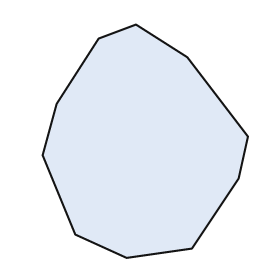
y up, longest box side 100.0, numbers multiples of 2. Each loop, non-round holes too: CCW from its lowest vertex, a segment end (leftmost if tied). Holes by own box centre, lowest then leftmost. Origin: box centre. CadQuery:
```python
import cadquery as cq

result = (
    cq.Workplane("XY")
    .moveTo(-8.0, -50.0)
    .lineTo(20.0, -46.0)
    .lineTo(40.0, -16.0)
    .lineTo(44.0, 2.0)
    .lineTo(18.0, 36.0)
    .lineTo(-4.0, 50.0)
    .lineTo(-20.0, 44.0)
    .lineTo(-38.0, 16.0)
    .lineTo(-44.0, -6.0)
    .lineTo(-30.0, -40.0)
    .close()
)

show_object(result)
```